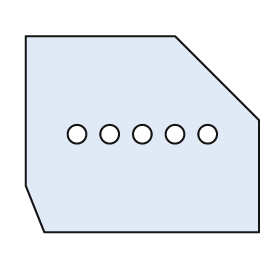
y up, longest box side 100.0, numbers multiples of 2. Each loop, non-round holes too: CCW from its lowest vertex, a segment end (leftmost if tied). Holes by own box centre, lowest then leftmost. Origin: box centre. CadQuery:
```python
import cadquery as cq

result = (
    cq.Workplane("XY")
    .moveTo(-42.0, -42.0)
    .lineTo(50.0, -42.0)
    .lineTo(50.0, 6.0)
    .lineTo(14.0, 42.0)
    .lineTo(-50.0, 42.0)
    .lineTo(-50.0, -22.0)
    .close()
    .moveTo(-28.0, 0.0)
    .circle(4.0)
    .moveTo(-14.0, 0.0)
    .circle(4.0)
    .moveTo(0.0, 0.0)
    .circle(4.0)
    .moveTo(14.0, 0.0)
    .circle(4.0)
    .moveTo(28.0, 0.0)
    .circle(4.0)
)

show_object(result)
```